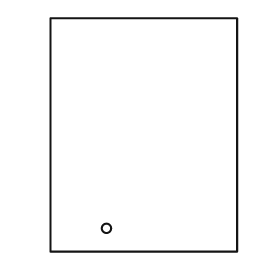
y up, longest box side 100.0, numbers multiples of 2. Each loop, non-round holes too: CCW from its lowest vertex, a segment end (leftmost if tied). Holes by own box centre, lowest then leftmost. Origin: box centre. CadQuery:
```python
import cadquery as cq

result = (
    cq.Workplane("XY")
    .moveTo(-40.0, -50.0)
    .lineTo(40.0, -50.0)
    .lineTo(40.0, 50.0)
    .lineTo(-40.0, 50.0)
    .close()
    .moveTo(-16.0, -40.0)
    .circle(2.0)
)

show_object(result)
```